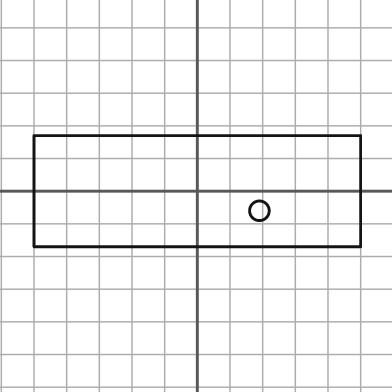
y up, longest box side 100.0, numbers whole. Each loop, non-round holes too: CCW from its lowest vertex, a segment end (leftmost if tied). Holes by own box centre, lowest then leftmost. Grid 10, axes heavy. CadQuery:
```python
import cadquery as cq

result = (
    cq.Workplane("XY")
    .moveTo(-50.0, -17.0)
    .lineTo(50.0, -17.0)
    .lineTo(50.0, 17.0)
    .lineTo(-50.0, 17.0)
    .close()
    .moveTo(19.0, -6.0)
    .circle(3.0)
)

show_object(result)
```